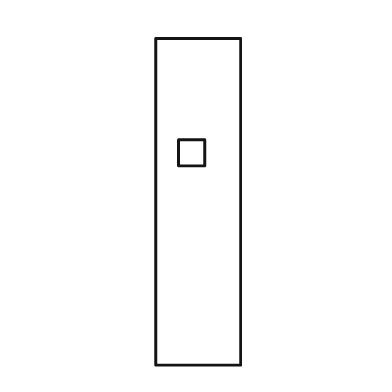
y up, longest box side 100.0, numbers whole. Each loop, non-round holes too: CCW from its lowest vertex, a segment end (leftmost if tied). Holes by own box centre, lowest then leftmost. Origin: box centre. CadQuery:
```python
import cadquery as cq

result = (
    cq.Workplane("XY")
    .moveTo(-13.0, -50.0)
    .lineTo(13.0, -50.0)
    .lineTo(13.0, 50.0)
    .lineTo(-13.0, 50.0)
    .close()
    .moveTo(-6.0, 11.0)
    .lineTo(2.0, 11.0)
    .lineTo(2.0, 19.0)
    .lineTo(-6.0, 19.0)
    .close()
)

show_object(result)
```